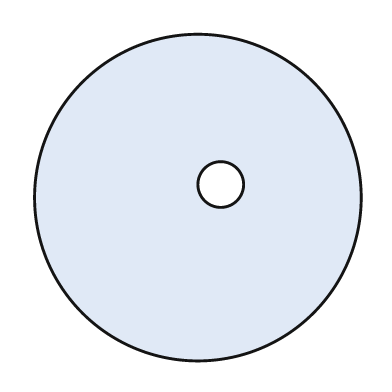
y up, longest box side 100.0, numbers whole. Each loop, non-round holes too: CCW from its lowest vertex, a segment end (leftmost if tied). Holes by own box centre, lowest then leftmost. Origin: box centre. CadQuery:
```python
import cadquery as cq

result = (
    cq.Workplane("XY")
    .moveTo(0.0, 0.0)
    .circle(50.0)
    .moveTo(7.0, 4.0)
    .circle(7.0)
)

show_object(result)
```